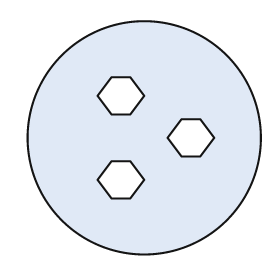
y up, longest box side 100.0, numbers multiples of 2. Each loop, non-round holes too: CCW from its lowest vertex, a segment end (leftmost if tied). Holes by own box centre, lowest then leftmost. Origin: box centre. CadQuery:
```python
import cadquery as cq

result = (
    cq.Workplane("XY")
    .moveTo(0.0, 0.0)
    .circle(50.0)
    .moveTo(-14.0, -26.0)
    .lineTo(-6.0, -26.0)
    .lineTo(0.0, -18.0)
    .lineTo(-6.0, -10.0)
    .lineTo(-14.0, -10.0)
    .lineTo(-20.0, -18.0)
    .close()
    .moveTo(16.0, -8.0)
    .lineTo(24.0, -8.0)
    .lineTo(30.0, 0.0)
    .lineTo(24.0, 8.0)
    .lineTo(16.0, 8.0)
    .lineTo(10.0, 0.0)
    .close()
    .moveTo(-14.0, 10.0)
    .lineTo(-6.0, 10.0)
    .lineTo(0.0, 18.0)
    .lineTo(-6.0, 26.0)
    .lineTo(-14.0, 26.0)
    .lineTo(-20.0, 18.0)
    .close()
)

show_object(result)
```